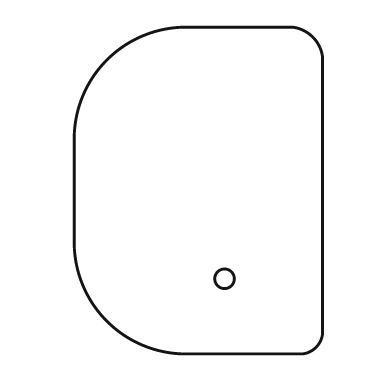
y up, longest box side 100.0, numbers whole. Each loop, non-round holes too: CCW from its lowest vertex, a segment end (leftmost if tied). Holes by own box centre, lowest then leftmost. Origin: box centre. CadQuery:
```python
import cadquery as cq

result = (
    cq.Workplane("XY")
    .moveTo(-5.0, -50.0)
    .lineTo(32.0, -50.0)
    .threePointArc((36.0, -48.0), (38.0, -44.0))
    .lineTo(38.0, 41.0)
    .threePointArc((35.0, 47.0), (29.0, 50.0))
    .lineTo(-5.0, 50.0)
    .threePointArc((-28.0, 40.0), (-38.0, 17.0))
    .lineTo(-38.0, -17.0)
    .threePointArc((-28.0, -40.0), (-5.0, -50.0))
    .close()
    .moveTo(8.0, -27.0)
    .circle(3.0)
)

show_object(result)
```